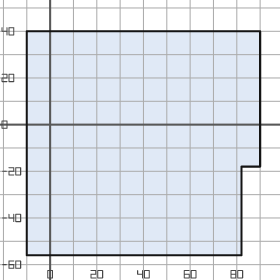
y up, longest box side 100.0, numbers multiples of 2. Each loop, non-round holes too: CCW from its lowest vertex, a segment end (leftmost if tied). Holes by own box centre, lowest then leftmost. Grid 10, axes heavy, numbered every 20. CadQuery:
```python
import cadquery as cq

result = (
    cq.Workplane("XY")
    .moveTo(-10.0, -56.0)
    .lineTo(82.0, -56.0)
    .lineTo(82.0, -18.0)
    .lineTo(90.0, -18.0)
    .lineTo(90.0, 40.0)
    .lineTo(-10.0, 40.0)
    .close()
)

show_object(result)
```